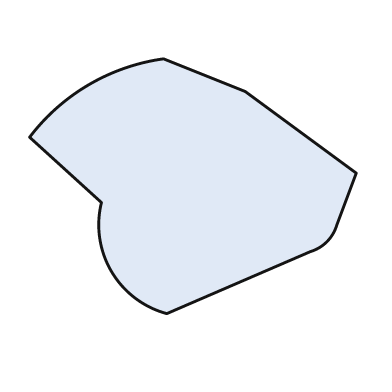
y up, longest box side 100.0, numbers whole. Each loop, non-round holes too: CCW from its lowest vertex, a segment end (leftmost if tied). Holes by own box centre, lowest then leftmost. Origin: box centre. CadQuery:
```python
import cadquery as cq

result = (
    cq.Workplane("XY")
    .moveTo(-8.0, -39.0)
    .lineTo(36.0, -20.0)
    .threePointArc((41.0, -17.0), (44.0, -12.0))
    .lineTo(50.0, 4.0)
    .lineTo(16.0, 29.0)
    .lineTo(-9.0, 39.0)
    .threePointArc((-32.0, 31.0), (-50.0, 15.0))
    .lineTo(-28.0, -5.0)
    .threePointArc((-25.0, -26.0), (-8.0, -39.0))
    .close()
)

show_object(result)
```